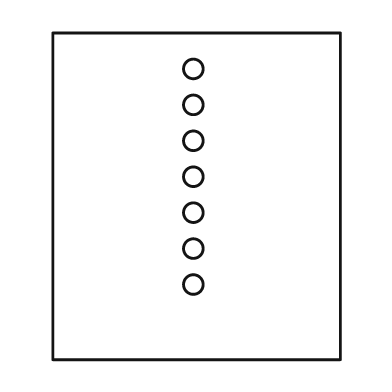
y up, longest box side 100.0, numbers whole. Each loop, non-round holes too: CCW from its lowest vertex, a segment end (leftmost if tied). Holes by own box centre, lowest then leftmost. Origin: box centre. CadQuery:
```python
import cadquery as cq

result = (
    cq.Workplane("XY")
    .moveTo(-44.0, -50.0)
    .lineTo(44.0, -50.0)
    .lineTo(44.0, 50.0)
    .lineTo(-44.0, 50.0)
    .close()
    .moveTo(-1.0, -27.0)
    .circle(3.0)
    .moveTo(-1.0, -16.0)
    .circle(3.0)
    .moveTo(-1.0, -5.0)
    .circle(3.0)
    .moveTo(-1.0, 6.0)
    .circle(3.0)
    .moveTo(-1.0, 17.0)
    .circle(3.0)
    .moveTo(-1.0, 28.0)
    .circle(3.0)
    .moveTo(-1.0, 39.0)
    .circle(3.0)
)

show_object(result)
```